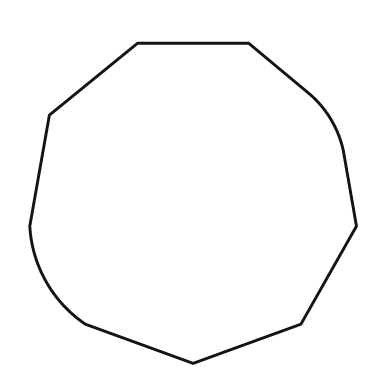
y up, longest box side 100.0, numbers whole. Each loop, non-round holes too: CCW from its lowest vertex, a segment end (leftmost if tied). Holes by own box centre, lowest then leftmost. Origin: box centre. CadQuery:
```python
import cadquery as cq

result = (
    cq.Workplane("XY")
    .moveTo(0.0, -49.0)
    .lineTo(33.0, -37.0)
    .lineTo(50.0, -7.0)
    .lineTo(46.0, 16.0)
    .threePointArc((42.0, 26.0), (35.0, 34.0))
    .lineTo(17.0, 49.0)
    .lineTo(-17.0, 49.0)
    .lineTo(-44.0, 27.0)
    .lineTo(-50.0, -7.0)
    .threePointArc((-45.0, -24.0), (-33.0, -37.0))
    .close()
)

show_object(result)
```